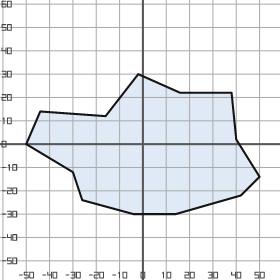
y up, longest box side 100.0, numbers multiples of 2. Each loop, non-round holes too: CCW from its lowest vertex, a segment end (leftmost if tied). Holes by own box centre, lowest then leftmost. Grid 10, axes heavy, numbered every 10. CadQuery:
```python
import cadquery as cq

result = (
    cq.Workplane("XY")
    .moveTo(-4.0, -30.0)
    .lineTo(14.0, -30.0)
    .lineTo(42.0, -22.0)
    .lineTo(50.0, -14.0)
    .lineTo(40.0, 2.0)
    .lineTo(38.0, 22.0)
    .lineTo(16.0, 22.0)
    .lineTo(-2.0, 30.0)
    .lineTo(-16.0, 12.0)
    .lineTo(-44.0, 14.0)
    .lineTo(-50.0, 0.0)
    .lineTo(-30.0, -12.0)
    .lineTo(-26.0, -24.0)
    .close()
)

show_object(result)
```